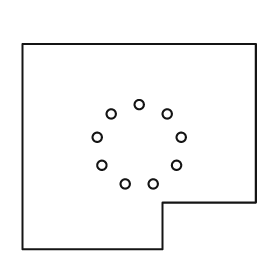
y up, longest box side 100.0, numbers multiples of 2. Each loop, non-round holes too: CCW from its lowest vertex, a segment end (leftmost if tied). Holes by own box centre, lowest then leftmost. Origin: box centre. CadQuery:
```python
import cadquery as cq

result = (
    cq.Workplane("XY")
    .moveTo(-50.0, -44.0)
    .lineTo(10.0, -44.0)
    .lineTo(10.0, -24.0)
    .lineTo(50.0, -24.0)
    .lineTo(50.0, 44.0)
    .lineTo(-50.0, 44.0)
    .close()
    .moveTo(-6.0, -16.0)
    .circle(2.0)
    .moveTo(6.0, -16.0)
    .circle(2.0)
    .moveTo(-16.0, -8.0)
    .circle(2.0)
    .moveTo(16.0, -8.0)
    .circle(2.0)
    .moveTo(-18.0, 4.0)
    .circle(2.0)
    .moveTo(18.0, 4.0)
    .circle(2.0)
    .moveTo(-12.0, 14.0)
    .circle(2.0)
    .moveTo(12.0, 14.0)
    .circle(2.0)
    .moveTo(0.0, 18.0)
    .circle(2.0)
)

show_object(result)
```